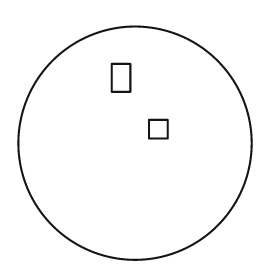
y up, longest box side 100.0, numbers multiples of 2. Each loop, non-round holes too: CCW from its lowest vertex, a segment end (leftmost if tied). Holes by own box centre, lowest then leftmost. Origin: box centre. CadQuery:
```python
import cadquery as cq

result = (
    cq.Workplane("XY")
    .moveTo(0.0, 0.0)
    .circle(50.0)
    .moveTo(6.0, 2.0)
    .lineTo(14.0, 2.0)
    .lineTo(14.0, 10.0)
    .lineTo(6.0, 10.0)
    .close()
    .moveTo(-10.0, 22.0)
    .lineTo(-2.0, 22.0)
    .lineTo(-2.0, 34.0)
    .lineTo(-10.0, 34.0)
    .close()
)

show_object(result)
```